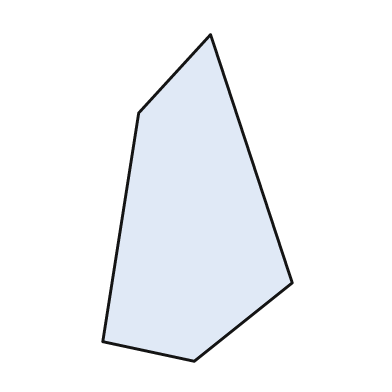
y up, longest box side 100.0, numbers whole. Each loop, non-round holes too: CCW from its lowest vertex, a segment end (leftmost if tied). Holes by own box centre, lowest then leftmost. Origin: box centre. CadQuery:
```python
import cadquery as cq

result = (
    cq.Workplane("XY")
    .moveTo(-1.0, -50.0)
    .lineTo(29.0, -26.0)
    .lineTo(4.0, 50.0)
    .lineTo(-18.0, 26.0)
    .lineTo(-29.0, -44.0)
    .close()
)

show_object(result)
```